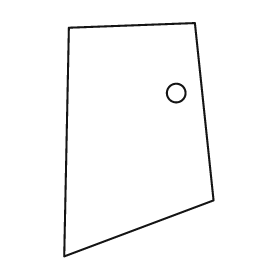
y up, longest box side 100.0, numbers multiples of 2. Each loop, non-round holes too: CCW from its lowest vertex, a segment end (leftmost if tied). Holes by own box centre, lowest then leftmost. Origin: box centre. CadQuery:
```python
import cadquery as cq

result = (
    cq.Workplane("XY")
    .moveTo(-32.0, -50.0)
    .lineTo(32.0, -26.0)
    .lineTo(24.0, 50.0)
    .lineTo(-30.0, 48.0)
    .close()
    .moveTo(16.0, 20.0)
    .circle(4.0)
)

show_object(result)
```